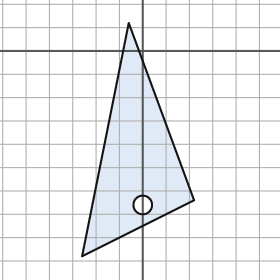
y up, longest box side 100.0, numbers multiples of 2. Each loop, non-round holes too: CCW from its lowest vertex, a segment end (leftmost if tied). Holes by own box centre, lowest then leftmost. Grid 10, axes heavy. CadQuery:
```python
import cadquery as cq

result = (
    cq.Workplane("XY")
    .moveTo(-26.0, -88.0)
    .lineTo(22.0, -64.0)
    .lineTo(-6.0, 12.0)
    .close()
    .moveTo(0.0, -66.0)
    .circle(4.0)
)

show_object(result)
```